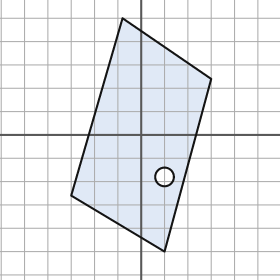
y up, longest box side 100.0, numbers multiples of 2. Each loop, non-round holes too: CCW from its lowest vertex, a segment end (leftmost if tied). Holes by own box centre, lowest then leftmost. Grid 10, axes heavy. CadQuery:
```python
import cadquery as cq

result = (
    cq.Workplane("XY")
    .moveTo(10.0, -50.0)
    .lineTo(30.0, 24.0)
    .lineTo(-8.0, 50.0)
    .lineTo(-30.0, -26.0)
    .close()
    .moveTo(10.0, -18.0)
    .circle(4.0)
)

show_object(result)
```